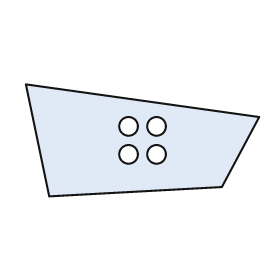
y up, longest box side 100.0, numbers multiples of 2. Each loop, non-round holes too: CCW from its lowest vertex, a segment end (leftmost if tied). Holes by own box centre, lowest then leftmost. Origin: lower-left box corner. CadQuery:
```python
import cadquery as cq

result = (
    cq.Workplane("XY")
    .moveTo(10.0, 0.0)
    .lineTo(84.0, 4.0)
    .lineTo(100.0, 34.0)
    .lineTo(0.0, 48.0)
    .close()
    .moveTo(44.0, 18.0)
    .circle(4.0)
    .moveTo(56.0, 18.0)
    .circle(4.0)
    .moveTo(44.0, 30.0)
    .circle(4.0)
    .moveTo(56.0, 30.0)
    .circle(4.0)
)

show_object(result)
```